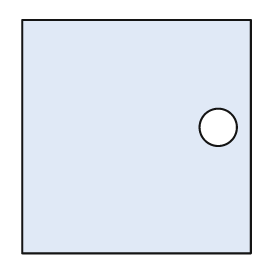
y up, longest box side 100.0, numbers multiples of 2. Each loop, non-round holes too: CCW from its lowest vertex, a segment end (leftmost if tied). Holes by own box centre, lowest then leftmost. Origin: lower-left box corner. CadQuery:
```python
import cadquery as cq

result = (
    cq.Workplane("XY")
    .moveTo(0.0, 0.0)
    .lineTo(98.0, 0.0)
    .lineTo(98.0, 100.0)
    .lineTo(0.0, 100.0)
    .close()
    .moveTo(84.0, 54.0)
    .circle(8.0)
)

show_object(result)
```